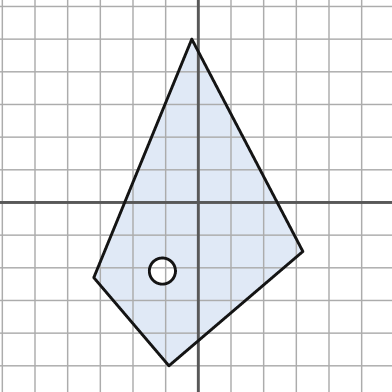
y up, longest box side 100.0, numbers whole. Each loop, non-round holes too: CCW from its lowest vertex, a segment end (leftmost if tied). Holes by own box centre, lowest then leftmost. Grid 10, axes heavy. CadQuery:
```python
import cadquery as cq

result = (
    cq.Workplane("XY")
    .moveTo(-9.0, -50.0)
    .lineTo(32.0, -15.0)
    .lineTo(-2.0, 50.0)
    .lineTo(-32.0, -23.0)
    .close()
    .moveTo(-11.0, -21.0)
    .circle(4.0)
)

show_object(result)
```